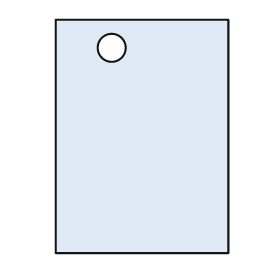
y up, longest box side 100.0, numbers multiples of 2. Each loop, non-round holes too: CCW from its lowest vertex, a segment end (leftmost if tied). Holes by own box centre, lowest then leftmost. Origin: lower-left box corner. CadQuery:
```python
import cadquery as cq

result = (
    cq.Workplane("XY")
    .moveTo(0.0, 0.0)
    .lineTo(74.0, 0.0)
    .lineTo(74.0, 100.0)
    .lineTo(0.0, 100.0)
    .close()
    .moveTo(24.0, 88.0)
    .circle(6.0)
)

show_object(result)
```